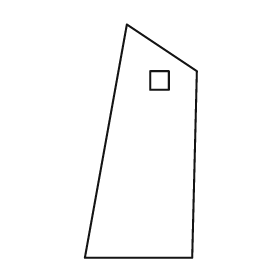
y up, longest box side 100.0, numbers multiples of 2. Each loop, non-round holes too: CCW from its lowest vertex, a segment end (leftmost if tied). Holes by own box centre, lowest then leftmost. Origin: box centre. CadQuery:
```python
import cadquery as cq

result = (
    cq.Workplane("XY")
    .moveTo(-24.0, -50.0)
    .lineTo(22.0, -50.0)
    .lineTo(24.0, 30.0)
    .lineTo(-6.0, 50.0)
    .close()
    .moveTo(4.0, 22.0)
    .lineTo(12.0, 22.0)
    .lineTo(12.0, 30.0)
    .lineTo(4.0, 30.0)
    .close()
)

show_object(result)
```